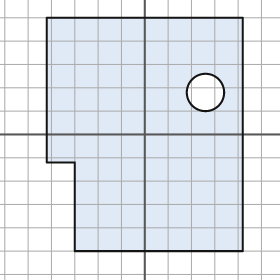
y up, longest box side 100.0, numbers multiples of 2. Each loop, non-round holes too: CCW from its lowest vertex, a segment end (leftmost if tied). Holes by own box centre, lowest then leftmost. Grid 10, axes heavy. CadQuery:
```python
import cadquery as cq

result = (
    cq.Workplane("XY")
    .moveTo(-30.0, -50.0)
    .lineTo(42.0, -50.0)
    .lineTo(42.0, 50.0)
    .lineTo(-42.0, 50.0)
    .lineTo(-42.0, -12.0)
    .lineTo(-30.0, -12.0)
    .close()
    .moveTo(26.0, 18.0)
    .circle(8.0)
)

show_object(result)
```